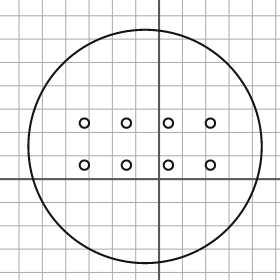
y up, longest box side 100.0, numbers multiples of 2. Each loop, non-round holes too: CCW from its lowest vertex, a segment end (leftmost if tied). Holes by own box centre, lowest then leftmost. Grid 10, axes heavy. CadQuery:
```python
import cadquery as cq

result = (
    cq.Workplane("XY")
    .moveTo(-6.0, 14.0)
    .circle(50.0)
    .moveTo(-32.0, 6.0)
    .circle(2.0)
    .moveTo(-14.0, 6.0)
    .circle(2.0)
    .moveTo(4.0, 6.0)
    .circle(2.0)
    .moveTo(22.0, 6.0)
    .circle(2.0)
    .moveTo(-32.0, 24.0)
    .circle(2.0)
    .moveTo(-14.0, 24.0)
    .circle(2.0)
    .moveTo(4.0, 24.0)
    .circle(2.0)
    .moveTo(22.0, 24.0)
    .circle(2.0)
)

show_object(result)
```